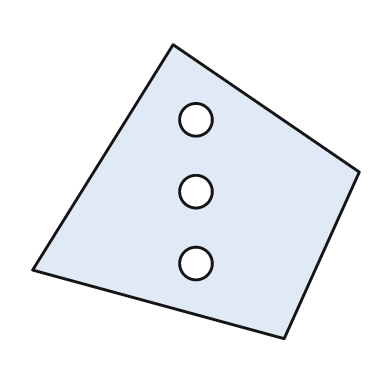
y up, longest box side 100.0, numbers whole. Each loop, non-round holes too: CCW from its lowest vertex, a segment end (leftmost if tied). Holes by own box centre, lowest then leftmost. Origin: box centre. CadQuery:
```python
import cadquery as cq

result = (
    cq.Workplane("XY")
    .moveTo(27.0, -45.0)
    .lineTo(50.0, 6.0)
    .lineTo(-7.0, 45.0)
    .lineTo(-50.0, -24.0)
    .close()
    .moveTo(0.0, -22.0)
    .circle(5.0)
    .moveTo(0.0, 0.0)
    .circle(5.0)
    .moveTo(0.0, 22.0)
    .circle(5.0)
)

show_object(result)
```